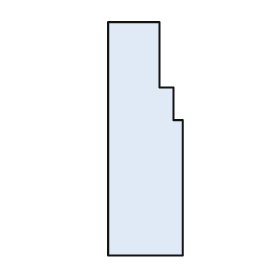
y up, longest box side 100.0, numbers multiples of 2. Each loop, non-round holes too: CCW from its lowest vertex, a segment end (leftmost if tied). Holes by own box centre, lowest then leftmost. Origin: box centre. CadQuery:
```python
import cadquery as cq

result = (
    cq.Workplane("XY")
    .moveTo(-16.0, -50.0)
    .lineTo(16.0, -50.0)
    .lineTo(16.0, 8.0)
    .lineTo(12.0, 8.0)
    .lineTo(12.0, 22.0)
    .lineTo(6.0, 22.0)
    .lineTo(6.0, 50.0)
    .lineTo(-16.0, 50.0)
    .close()
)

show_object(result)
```